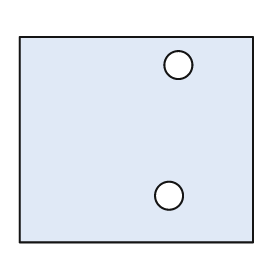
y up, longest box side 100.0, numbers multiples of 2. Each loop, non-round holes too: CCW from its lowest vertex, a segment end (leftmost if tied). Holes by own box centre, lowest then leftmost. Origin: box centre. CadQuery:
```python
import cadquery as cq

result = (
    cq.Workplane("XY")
    .moveTo(-50.0, -44.0)
    .lineTo(50.0, -44.0)
    .lineTo(50.0, 44.0)
    .lineTo(-50.0, 44.0)
    .close()
    .moveTo(14.0, -24.0)
    .circle(6.0)
    .moveTo(18.0, 32.0)
    .circle(6.0)
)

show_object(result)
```